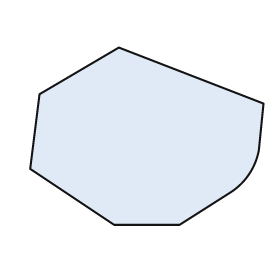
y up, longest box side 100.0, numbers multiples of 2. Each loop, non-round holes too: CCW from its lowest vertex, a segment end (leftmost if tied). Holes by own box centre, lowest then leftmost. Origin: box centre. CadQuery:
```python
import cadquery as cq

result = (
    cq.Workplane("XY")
    .moveTo(-14.0, -38.0)
    .lineTo(14.0, -38.0)
    .lineTo(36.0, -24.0)
    .threePointArc((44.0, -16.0), (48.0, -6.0))
    .lineTo(50.0, 14.0)
    .lineTo(-12.0, 38.0)
    .lineTo(-46.0, 18.0)
    .lineTo(-50.0, -14.0)
    .close()
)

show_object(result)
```